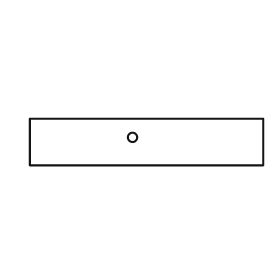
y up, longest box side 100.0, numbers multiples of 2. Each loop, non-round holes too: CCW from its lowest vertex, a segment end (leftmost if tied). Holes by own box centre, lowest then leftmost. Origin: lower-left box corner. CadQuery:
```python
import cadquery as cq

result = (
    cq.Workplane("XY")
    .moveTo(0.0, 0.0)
    .lineTo(100.0, 0.0)
    .lineTo(100.0, 20.0)
    .lineTo(0.0, 20.0)
    .close()
    .moveTo(44.0, 12.0)
    .circle(2.0)
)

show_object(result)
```